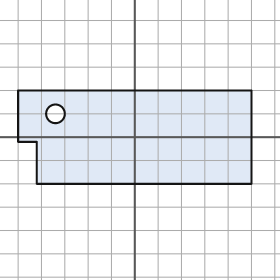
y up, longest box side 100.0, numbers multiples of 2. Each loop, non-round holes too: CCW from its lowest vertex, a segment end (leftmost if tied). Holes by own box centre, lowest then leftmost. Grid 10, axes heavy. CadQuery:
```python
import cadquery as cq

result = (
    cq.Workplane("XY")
    .moveTo(-42.0, -20.0)
    .lineTo(50.0, -20.0)
    .lineTo(50.0, 20.0)
    .lineTo(-50.0, 20.0)
    .lineTo(-50.0, -2.0)
    .lineTo(-42.0, -2.0)
    .close()
    .moveTo(-34.0, 10.0)
    .circle(4.0)
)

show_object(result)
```